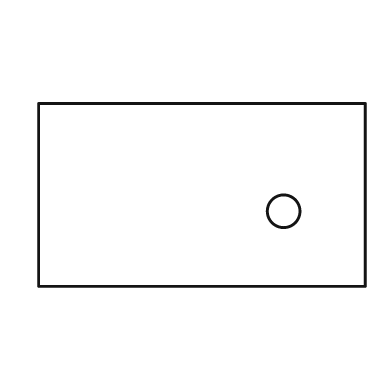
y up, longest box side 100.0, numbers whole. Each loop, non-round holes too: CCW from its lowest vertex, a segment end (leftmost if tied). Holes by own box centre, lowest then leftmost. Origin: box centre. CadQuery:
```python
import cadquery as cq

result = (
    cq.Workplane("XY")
    .moveTo(-50.0, -28.0)
    .lineTo(50.0, -28.0)
    .lineTo(50.0, 28.0)
    .lineTo(-50.0, 28.0)
    .close()
    .moveTo(25.0, -5.0)
    .circle(5.0)
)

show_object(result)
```